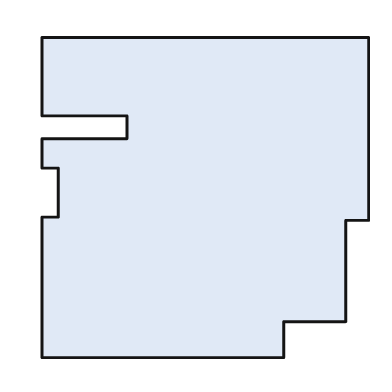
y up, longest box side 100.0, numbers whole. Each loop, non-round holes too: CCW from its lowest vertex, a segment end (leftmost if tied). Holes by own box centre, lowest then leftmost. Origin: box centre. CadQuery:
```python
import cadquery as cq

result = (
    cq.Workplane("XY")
    .moveTo(-50.0, -49.0)
    .lineTo(24.0, -49.0)
    .lineTo(24.0, -38.0)
    .lineTo(43.0, -38.0)
    .lineTo(43.0, -7.0)
    .lineTo(50.0, -7.0)
    .lineTo(50.0, 49.0)
    .lineTo(-50.0, 49.0)
    .lineTo(-50.0, 25.0)
    .lineTo(-24.0, 25.0)
    .lineTo(-24.0, 18.0)
    .lineTo(-50.0, 18.0)
    .lineTo(-50.0, 9.0)
    .lineTo(-45.0, 9.0)
    .lineTo(-45.0, -6.0)
    .lineTo(-50.0, -6.0)
    .close()
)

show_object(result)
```